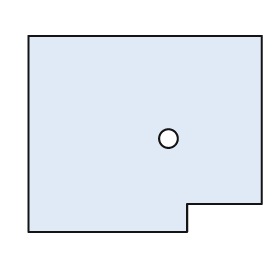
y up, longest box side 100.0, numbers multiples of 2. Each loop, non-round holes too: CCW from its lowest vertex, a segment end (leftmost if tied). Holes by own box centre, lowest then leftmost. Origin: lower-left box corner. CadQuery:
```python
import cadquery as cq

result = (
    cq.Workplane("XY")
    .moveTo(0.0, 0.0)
    .lineTo(68.0, 0.0)
    .lineTo(68.0, 12.0)
    .lineTo(100.0, 12.0)
    .lineTo(100.0, 84.0)
    .lineTo(0.0, 84.0)
    .close()
    .moveTo(60.0, 40.0)
    .circle(4.0)
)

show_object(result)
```